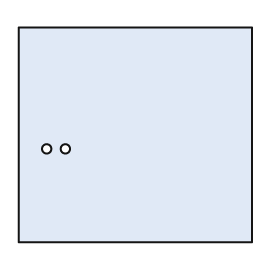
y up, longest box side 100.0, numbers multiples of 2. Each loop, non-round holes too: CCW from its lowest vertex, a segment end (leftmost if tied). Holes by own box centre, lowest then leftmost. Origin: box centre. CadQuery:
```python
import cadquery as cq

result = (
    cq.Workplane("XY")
    .moveTo(-50.0, -46.0)
    .lineTo(50.0, -46.0)
    .lineTo(50.0, 46.0)
    .lineTo(-50.0, 46.0)
    .close()
    .moveTo(-38.0, -6.0)
    .circle(2.0)
    .moveTo(-30.0, -6.0)
    .circle(2.0)
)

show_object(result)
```